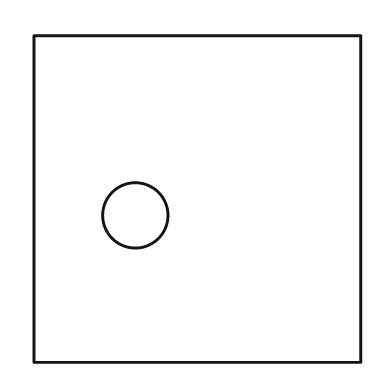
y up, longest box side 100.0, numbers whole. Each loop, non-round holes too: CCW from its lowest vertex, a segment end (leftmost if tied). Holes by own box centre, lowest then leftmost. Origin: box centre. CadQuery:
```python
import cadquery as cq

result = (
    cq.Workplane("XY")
    .moveTo(-50.0, -50.0)
    .lineTo(50.0, -50.0)
    .lineTo(50.0, 50.0)
    .lineTo(-50.0, 50.0)
    .close()
    .moveTo(-19.0, -5.0)
    .circle(10.0)
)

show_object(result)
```